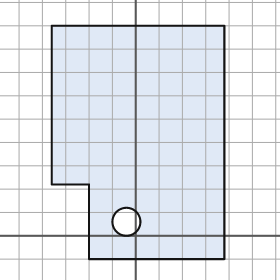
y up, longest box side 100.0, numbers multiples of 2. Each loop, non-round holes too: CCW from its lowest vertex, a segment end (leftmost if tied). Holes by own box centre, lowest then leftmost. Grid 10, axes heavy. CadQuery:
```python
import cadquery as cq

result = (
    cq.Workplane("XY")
    .moveTo(-20.0, -10.0)
    .lineTo(38.0, -10.0)
    .lineTo(38.0, 90.0)
    .lineTo(-36.0, 90.0)
    .lineTo(-36.0, 22.0)
    .lineTo(-20.0, 22.0)
    .close()
    .moveTo(-4.0, 6.0)
    .circle(6.0)
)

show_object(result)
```